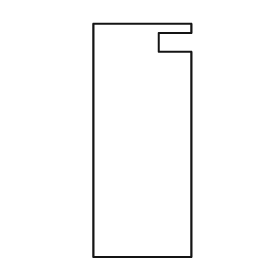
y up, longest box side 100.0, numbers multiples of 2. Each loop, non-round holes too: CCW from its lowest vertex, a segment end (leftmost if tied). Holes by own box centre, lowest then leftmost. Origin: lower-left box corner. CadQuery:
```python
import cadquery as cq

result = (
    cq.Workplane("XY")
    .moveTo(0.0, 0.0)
    .lineTo(42.0, 0.0)
    .lineTo(42.0, 88.0)
    .lineTo(28.0, 88.0)
    .lineTo(28.0, 96.0)
    .lineTo(42.0, 96.0)
    .lineTo(42.0, 100.0)
    .lineTo(0.0, 100.0)
    .close()
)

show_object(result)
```